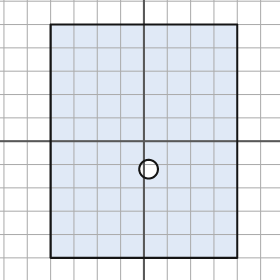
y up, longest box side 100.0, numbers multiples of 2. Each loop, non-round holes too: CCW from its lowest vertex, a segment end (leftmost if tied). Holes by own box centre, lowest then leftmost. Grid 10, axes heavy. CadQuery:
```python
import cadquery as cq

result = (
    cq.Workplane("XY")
    .moveTo(-40.0, -50.0)
    .lineTo(40.0, -50.0)
    .lineTo(40.0, 50.0)
    .lineTo(-40.0, 50.0)
    .close()
    .moveTo(2.0, -12.0)
    .circle(4.0)
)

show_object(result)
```